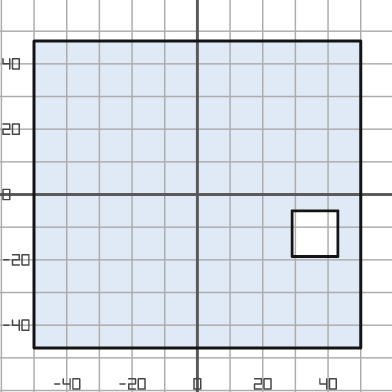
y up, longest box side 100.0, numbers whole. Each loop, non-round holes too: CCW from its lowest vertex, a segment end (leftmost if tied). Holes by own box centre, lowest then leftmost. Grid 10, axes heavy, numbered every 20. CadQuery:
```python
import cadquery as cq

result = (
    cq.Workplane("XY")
    .moveTo(-50.0, -47.0)
    .lineTo(50.0, -47.0)
    .lineTo(50.0, 47.0)
    .lineTo(-50.0, 47.0)
    .close()
    .moveTo(29.0, -19.0)
    .lineTo(43.0, -19.0)
    .lineTo(43.0, -5.0)
    .lineTo(29.0, -5.0)
    .close()
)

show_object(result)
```